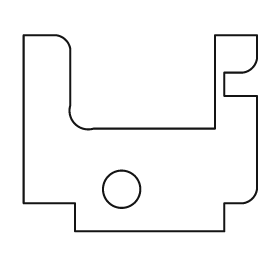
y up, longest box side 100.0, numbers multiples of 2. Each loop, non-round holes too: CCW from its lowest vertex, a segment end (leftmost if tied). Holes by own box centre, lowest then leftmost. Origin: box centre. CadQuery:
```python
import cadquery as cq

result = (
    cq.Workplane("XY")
    .moveTo(-28.0, -42.0)
    .lineTo(36.0, -42.0)
    .lineTo(36.0, -30.0)
    .lineTo(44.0, -30.0)
    .threePointArc((48.0, -28.0), (50.0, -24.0))
    .lineTo(50.0, 16.0)
    .lineTo(36.0, 16.0)
    .lineTo(36.0, 26.0)
    .lineTo(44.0, 26.0)
    .threePointArc((48.0, 28.0), (50.0, 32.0))
    .lineTo(50.0, 42.0)
    .lineTo(32.0, 42.0)
    .lineTo(32.0, 2.0)
    .lineTo(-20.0, 2.0)
    .threePointArc((-28.0, 4.0), (-30.0, 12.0))
    .lineTo(-30.0, 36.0)
    .threePointArc((-32.0, 40.0), (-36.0, 42.0))
    .lineTo(-50.0, 42.0)
    .lineTo(-50.0, -30.0)
    .lineTo(-28.0, -30.0)
    .close()
    .moveTo(-8.0, -24.0)
    .circle(8.0)
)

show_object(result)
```